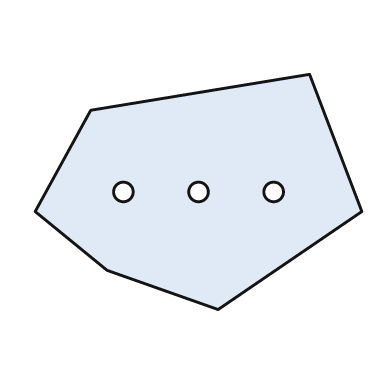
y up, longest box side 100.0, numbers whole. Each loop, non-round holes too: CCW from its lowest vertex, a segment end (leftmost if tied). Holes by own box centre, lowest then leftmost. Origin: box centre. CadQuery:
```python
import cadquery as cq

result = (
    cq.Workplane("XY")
    .moveTo(6.0, -36.0)
    .lineTo(50.0, -6.0)
    .lineTo(34.0, 36.0)
    .lineTo(-33.0, 25.0)
    .lineTo(-50.0, -6.0)
    .lineTo(-28.0, -24.0)
    .close()
    .moveTo(-23.0, 0.0)
    .circle(3.0)
    .moveTo(0.0, 0.0)
    .circle(3.0)
    .moveTo(23.0, 0.0)
    .circle(3.0)
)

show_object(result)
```